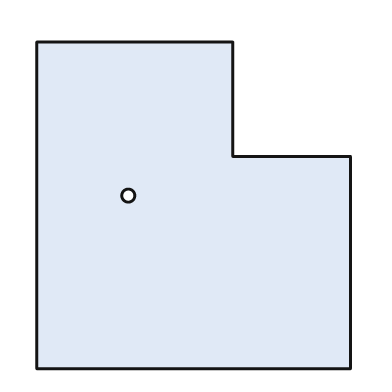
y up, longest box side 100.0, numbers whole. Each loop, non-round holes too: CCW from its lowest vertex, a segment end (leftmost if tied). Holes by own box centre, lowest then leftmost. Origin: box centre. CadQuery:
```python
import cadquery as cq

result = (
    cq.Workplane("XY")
    .moveTo(-48.0, -50.0)
    .lineTo(48.0, -50.0)
    .lineTo(48.0, 15.0)
    .lineTo(12.0, 15.0)
    .lineTo(12.0, 50.0)
    .lineTo(-48.0, 50.0)
    .close()
    .moveTo(-20.0, 3.0)
    .circle(2.0)
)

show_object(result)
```